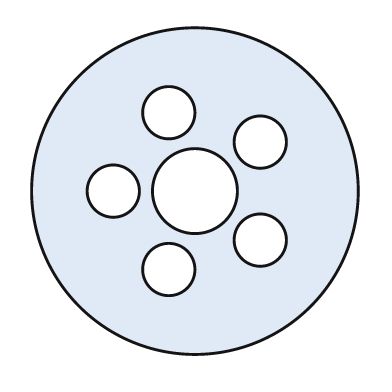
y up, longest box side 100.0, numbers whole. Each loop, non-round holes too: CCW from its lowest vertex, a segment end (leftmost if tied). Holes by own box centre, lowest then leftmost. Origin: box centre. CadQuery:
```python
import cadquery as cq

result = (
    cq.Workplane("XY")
    .moveTo(0.0, 0.0)
    .circle(50.0)
    .moveTo(-8.0, -24.0)
    .circle(8.0)
    .moveTo(20.0, -15.0)
    .circle(8.0)
    .moveTo(-25.0, 0.0)
    .circle(8.0)
    .moveTo(0.0, 0.0)
    .circle(13.0)
    .moveTo(20.0, 15.0)
    .circle(8.0)
    .moveTo(-8.0, 24.0)
    .circle(8.0)
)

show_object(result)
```